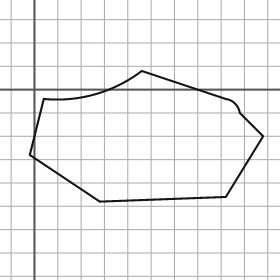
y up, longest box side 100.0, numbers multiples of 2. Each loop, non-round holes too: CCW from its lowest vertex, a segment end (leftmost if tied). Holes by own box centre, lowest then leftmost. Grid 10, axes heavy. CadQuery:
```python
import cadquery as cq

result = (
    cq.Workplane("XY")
    .moveTo(28.0, -48.0)
    .lineTo(82.0, -46.0)
    .lineTo(98.0, -20.0)
    .lineTo(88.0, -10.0)
    .threePointArc((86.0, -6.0), (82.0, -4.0))
    .lineTo(46.0, 8.0)
    .threePointArc((26.0, -2.0), (4.0, -4.0))
    .lineTo(-2.0, -28.0)
    .close()
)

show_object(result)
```